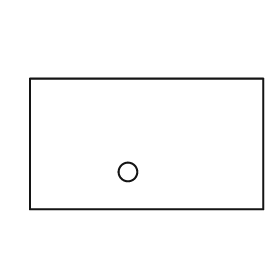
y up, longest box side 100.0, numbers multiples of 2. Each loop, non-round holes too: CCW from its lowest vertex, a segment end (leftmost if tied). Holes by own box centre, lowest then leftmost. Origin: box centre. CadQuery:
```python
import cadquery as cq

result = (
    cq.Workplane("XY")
    .moveTo(-50.0, -28.0)
    .lineTo(50.0, -28.0)
    .lineTo(50.0, 28.0)
    .lineTo(-50.0, 28.0)
    .close()
    .moveTo(-8.0, -12.0)
    .circle(4.0)
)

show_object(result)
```